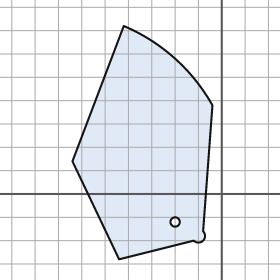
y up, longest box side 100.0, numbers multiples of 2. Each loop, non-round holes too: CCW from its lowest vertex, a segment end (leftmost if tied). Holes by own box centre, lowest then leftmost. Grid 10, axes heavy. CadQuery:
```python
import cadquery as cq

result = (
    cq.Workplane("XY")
    .moveTo(-44.0, -28.0)
    .lineTo(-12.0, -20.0)
    .threePointArc((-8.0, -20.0), (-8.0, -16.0))
    .lineTo(-4.0, 38.0)
    .threePointArc((-20.0, 58.0), (-42.0, 72.0))
    .lineTo(-64.0, 14.0)
    .close()
    .moveTo(-20.0, -12.0)
    .circle(2.0)
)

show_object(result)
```